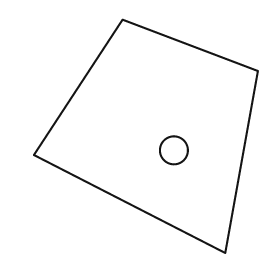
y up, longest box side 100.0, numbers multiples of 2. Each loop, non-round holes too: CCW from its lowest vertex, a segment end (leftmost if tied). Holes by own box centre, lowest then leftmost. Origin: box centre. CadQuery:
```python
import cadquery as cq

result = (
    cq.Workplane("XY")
    .moveTo(34.0, -50.0)
    .lineTo(48.0, 28.0)
    .lineTo(-10.0, 50.0)
    .lineTo(-48.0, -8.0)
    .close()
    .moveTo(12.0, -6.0)
    .circle(6.0)
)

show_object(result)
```